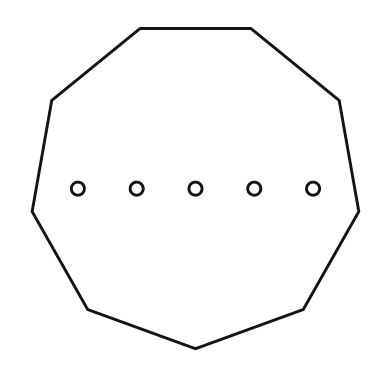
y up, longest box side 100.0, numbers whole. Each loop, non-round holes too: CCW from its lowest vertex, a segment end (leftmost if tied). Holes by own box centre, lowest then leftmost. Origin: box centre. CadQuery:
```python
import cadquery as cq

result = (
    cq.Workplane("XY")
    .moveTo(0.0, -49.0)
    .lineTo(33.0, -37.0)
    .lineTo(50.0, -7.0)
    .lineTo(44.0, 27.0)
    .lineTo(17.0, 49.0)
    .lineTo(-17.0, 49.0)
    .lineTo(-44.0, 27.0)
    .lineTo(-50.0, -7.0)
    .lineTo(-33.0, -37.0)
    .close()
    .moveTo(-36.0, 0.0)
    .circle(2.0)
    .moveTo(-18.0, 0.0)
    .circle(2.0)
    .moveTo(0.0, 0.0)
    .circle(2.0)
    .moveTo(18.0, 0.0)
    .circle(2.0)
    .moveTo(36.0, 0.0)
    .circle(2.0)
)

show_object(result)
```